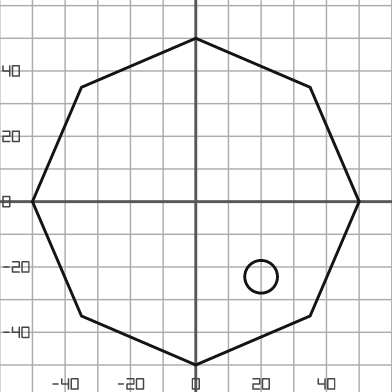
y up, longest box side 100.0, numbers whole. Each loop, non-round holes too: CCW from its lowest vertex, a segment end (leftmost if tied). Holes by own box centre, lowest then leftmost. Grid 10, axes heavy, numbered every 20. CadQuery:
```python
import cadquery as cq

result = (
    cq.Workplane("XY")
    .moveTo(0.0, -50.0)
    .lineTo(35.0, -35.0)
    .lineTo(50.0, 0.0)
    .lineTo(35.0, 35.0)
    .lineTo(0.0, 50.0)
    .lineTo(-35.0, 35.0)
    .lineTo(-50.0, 0.0)
    .lineTo(-35.0, -35.0)
    .close()
    .moveTo(20.0, -23.0)
    .circle(5.0)
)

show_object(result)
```